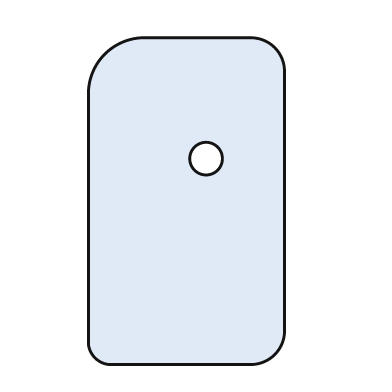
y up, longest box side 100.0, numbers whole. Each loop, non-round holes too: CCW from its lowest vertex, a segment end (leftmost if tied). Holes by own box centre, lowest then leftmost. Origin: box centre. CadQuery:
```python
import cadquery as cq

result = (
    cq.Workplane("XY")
    .moveTo(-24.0, -50.0)
    .lineTo(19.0, -50.0)
    .threePointArc((27.0, -47.0), (30.0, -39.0))
    .lineTo(30.0, 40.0)
    .threePointArc((27.0, 47.0), (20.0, 50.0))
    .lineTo(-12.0, 50.0)
    .threePointArc((-25.0, 45.0), (-30.0, 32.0))
    .lineTo(-30.0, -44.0)
    .threePointArc((-28.0, -48.0), (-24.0, -50.0))
    .close()
    .moveTo(6.0, 13.0)
    .circle(5.0)
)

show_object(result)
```